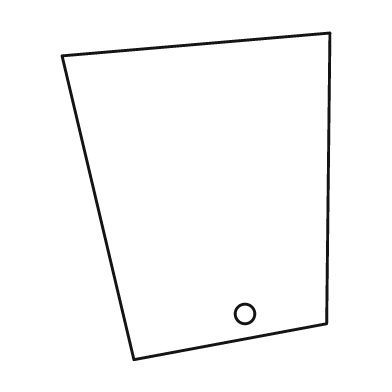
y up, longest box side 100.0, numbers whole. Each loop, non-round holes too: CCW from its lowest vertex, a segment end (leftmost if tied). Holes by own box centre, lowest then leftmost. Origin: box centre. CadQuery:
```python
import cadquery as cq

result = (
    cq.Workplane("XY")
    .moveTo(-19.0, -50.0)
    .lineTo(40.0, -39.0)
    .lineTo(41.0, 50.0)
    .lineTo(-41.0, 43.0)
    .close()
    .moveTo(15.0, -36.0)
    .circle(3.0)
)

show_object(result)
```